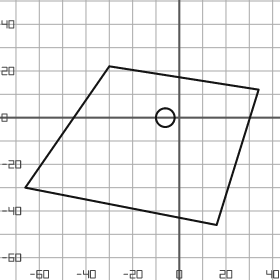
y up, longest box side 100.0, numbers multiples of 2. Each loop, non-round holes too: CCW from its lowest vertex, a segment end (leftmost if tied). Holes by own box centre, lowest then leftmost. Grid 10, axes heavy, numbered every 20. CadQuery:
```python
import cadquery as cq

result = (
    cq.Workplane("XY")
    .moveTo(16.0, -46.0)
    .lineTo(34.0, 12.0)
    .lineTo(-30.0, 22.0)
    .lineTo(-66.0, -30.0)
    .close()
    .moveTo(-6.0, 0.0)
    .circle(4.0)
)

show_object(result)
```